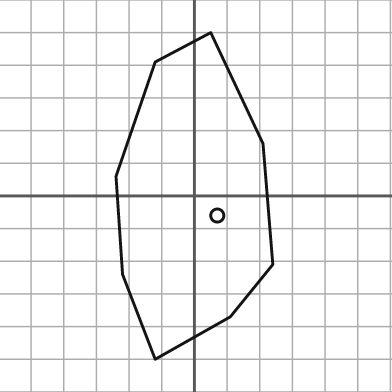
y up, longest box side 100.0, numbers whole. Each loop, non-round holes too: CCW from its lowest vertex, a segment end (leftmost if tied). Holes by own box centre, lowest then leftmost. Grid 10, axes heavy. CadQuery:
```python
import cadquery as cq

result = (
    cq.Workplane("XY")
    .moveTo(-12.0, -50.0)
    .lineTo(11.0, -37.0)
    .lineTo(24.0, -21.0)
    .lineTo(21.0, 16.0)
    .lineTo(5.0, 50.0)
    .lineTo(-12.0, 41.0)
    .lineTo(-24.0, 6.0)
    .lineTo(-22.0, -24.0)
    .close()
    .moveTo(7.0, -6.0)
    .circle(2.0)
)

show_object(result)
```